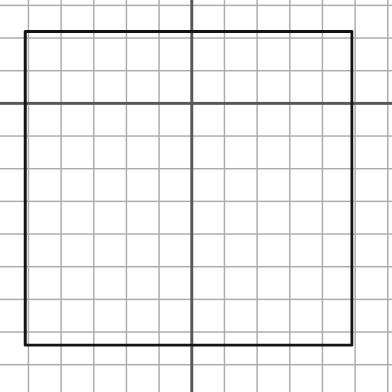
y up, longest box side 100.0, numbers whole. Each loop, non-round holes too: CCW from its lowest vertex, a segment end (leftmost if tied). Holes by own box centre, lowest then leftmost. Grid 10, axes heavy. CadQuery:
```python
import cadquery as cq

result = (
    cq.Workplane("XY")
    .moveTo(-51.0, -74.0)
    .lineTo(49.0, -74.0)
    .lineTo(49.0, 22.0)
    .lineTo(-51.0, 22.0)
    .close()
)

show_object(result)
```